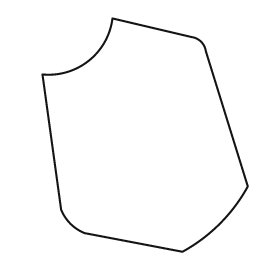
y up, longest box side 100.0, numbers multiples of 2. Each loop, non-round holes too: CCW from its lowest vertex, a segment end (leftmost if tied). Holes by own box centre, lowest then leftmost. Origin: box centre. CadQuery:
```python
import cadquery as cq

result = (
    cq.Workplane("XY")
    .moveTo(16.0, -50.0)
    .threePointArc((32.0, -38.0), (44.0, -22.0))
    .lineTo(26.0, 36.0)
    .threePointArc((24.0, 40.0), (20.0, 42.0))
    .lineTo(-14.0, 50.0)
    .threePointArc((-24.0, 32.0), (-44.0, 26.0))
    .lineTo(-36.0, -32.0)
    .threePointArc((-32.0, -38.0), (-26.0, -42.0))
    .close()
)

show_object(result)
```